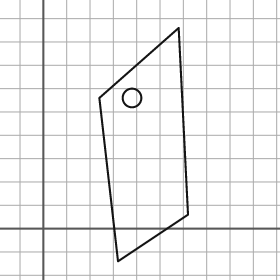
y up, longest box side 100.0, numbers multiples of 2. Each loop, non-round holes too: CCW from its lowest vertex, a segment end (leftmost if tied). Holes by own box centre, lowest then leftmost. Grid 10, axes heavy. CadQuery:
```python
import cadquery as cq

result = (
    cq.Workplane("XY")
    .moveTo(32.0, -14.0)
    .lineTo(62.0, 6.0)
    .lineTo(58.0, 86.0)
    .lineTo(24.0, 56.0)
    .close()
    .moveTo(38.0, 56.0)
    .circle(4.0)
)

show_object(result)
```